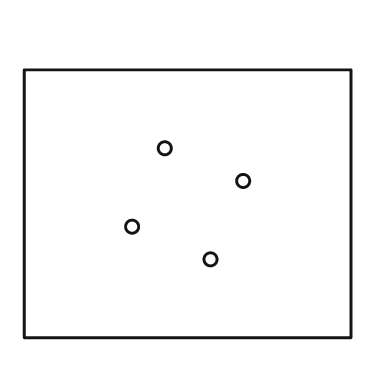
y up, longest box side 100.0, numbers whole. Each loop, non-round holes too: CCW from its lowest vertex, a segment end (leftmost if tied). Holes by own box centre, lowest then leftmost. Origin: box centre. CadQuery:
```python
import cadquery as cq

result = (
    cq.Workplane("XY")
    .moveTo(-50.0, -41.0)
    .lineTo(50.0, -41.0)
    .lineTo(50.0, 41.0)
    .lineTo(-50.0, 41.0)
    .close()
    .moveTo(7.0, -17.0)
    .circle(2.0)
    .moveTo(-17.0, -7.0)
    .circle(2.0)
    .moveTo(17.0, 7.0)
    .circle(2.0)
    .moveTo(-7.0, 17.0)
    .circle(2.0)
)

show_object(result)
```